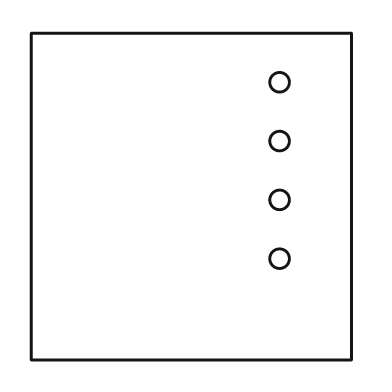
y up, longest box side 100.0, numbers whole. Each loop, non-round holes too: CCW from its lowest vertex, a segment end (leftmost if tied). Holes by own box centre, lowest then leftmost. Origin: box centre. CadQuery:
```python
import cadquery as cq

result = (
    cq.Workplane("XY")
    .moveTo(-49.0, -50.0)
    .lineTo(49.0, -50.0)
    .lineTo(49.0, 50.0)
    .lineTo(-49.0, 50.0)
    .close()
    .moveTo(27.0, -19.0)
    .circle(3.0)
    .moveTo(27.0, -1.0)
    .circle(3.0)
    .moveTo(27.0, 17.0)
    .circle(3.0)
    .moveTo(27.0, 35.0)
    .circle(3.0)
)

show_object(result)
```